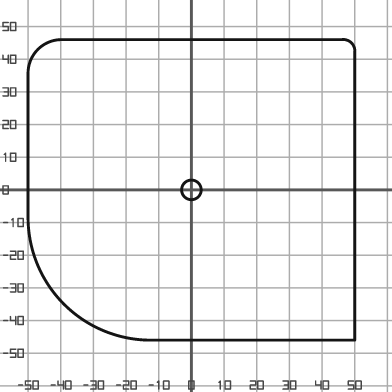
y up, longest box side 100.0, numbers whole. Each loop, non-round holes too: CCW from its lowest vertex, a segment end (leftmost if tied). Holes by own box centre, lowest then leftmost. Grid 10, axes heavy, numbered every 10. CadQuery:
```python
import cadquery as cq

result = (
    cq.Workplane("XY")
    .moveTo(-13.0, -46.0)
    .lineTo(50.0, -46.0)
    .lineTo(50.0, 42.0)
    .threePointArc((49.0, 45.0), (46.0, 46.0))
    .lineTo(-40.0, 46.0)
    .threePointArc((-47.0, 43.0), (-50.0, 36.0))
    .lineTo(-50.0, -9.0)
    .threePointArc((-39.0, -35.0), (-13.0, -46.0))
    .close()
    .moveTo(0.0, 0.0)
    .circle(3.0)
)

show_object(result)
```